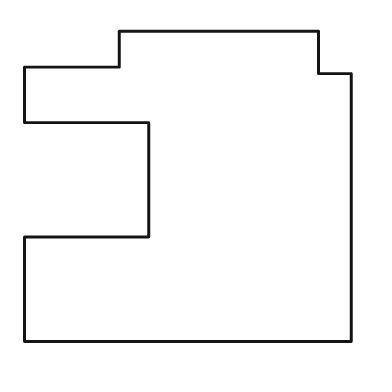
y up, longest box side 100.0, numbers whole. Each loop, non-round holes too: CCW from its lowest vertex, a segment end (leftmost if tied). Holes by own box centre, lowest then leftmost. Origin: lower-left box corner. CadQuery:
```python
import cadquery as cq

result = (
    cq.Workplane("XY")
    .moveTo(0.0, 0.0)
    .lineTo(100.0, 0.0)
    .lineTo(100.0, 82.0)
    .lineTo(90.0, 82.0)
    .lineTo(90.0, 95.0)
    .lineTo(29.0, 95.0)
    .lineTo(29.0, 84.0)
    .lineTo(0.0, 84.0)
    .lineTo(0.0, 67.0)
    .lineTo(38.0, 67.0)
    .lineTo(38.0, 32.0)
    .lineTo(0.0, 32.0)
    .close()
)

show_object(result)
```